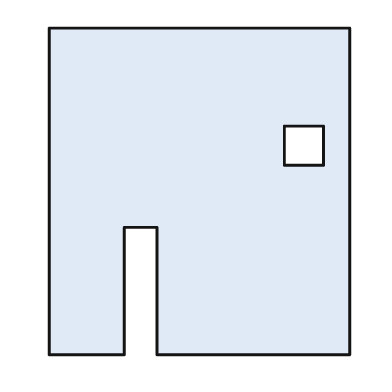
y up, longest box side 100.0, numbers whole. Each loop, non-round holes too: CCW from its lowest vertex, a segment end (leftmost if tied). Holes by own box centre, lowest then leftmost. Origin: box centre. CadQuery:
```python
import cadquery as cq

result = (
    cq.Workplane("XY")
    .moveTo(-46.0, -50.0)
    .lineTo(-23.0, -50.0)
    .lineTo(-23.0, -11.0)
    .lineTo(-13.0, -11.0)
    .lineTo(-13.0, -50.0)
    .lineTo(46.0, -50.0)
    .lineTo(46.0, 50.0)
    .lineTo(-46.0, 50.0)
    .close()
    .moveTo(26.0, 8.0)
    .lineTo(38.0, 8.0)
    .lineTo(38.0, 20.0)
    .lineTo(26.0, 20.0)
    .close()
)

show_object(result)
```